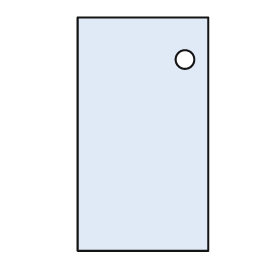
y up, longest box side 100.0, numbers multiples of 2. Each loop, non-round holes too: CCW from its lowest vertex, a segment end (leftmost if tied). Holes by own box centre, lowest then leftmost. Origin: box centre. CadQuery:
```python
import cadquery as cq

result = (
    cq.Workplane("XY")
    .moveTo(-28.0, -50.0)
    .lineTo(28.0, -50.0)
    .lineTo(28.0, 50.0)
    .lineTo(-28.0, 50.0)
    .close()
    .moveTo(18.0, 32.0)
    .circle(4.0)
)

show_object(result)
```